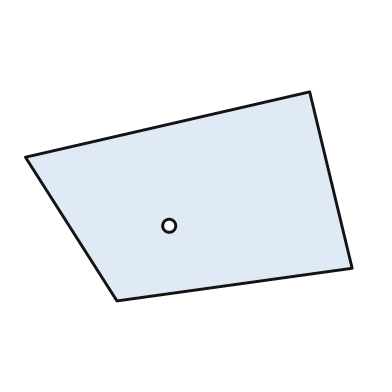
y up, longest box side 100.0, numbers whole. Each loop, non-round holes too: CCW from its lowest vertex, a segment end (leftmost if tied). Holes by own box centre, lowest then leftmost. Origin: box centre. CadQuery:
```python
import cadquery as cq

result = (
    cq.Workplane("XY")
    .moveTo(-22.0, -32.0)
    .lineTo(50.0, -22.0)
    .lineTo(37.0, 32.0)
    .lineTo(-50.0, 12.0)
    .close()
    .moveTo(-6.0, -9.0)
    .circle(2.0)
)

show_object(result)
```